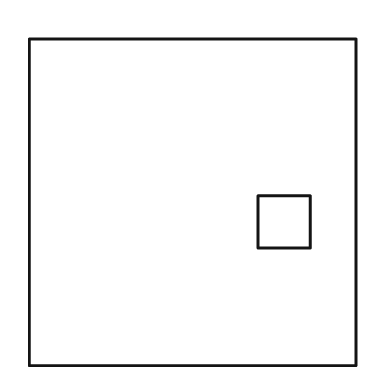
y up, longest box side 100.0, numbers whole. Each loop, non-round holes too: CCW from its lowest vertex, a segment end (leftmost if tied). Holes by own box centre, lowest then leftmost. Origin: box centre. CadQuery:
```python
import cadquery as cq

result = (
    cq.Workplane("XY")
    .moveTo(-50.0, -50.0)
    .lineTo(50.0, -50.0)
    .lineTo(50.0, 50.0)
    .lineTo(-50.0, 50.0)
    .close()
    .moveTo(20.0, -14.0)
    .lineTo(36.0, -14.0)
    .lineTo(36.0, 2.0)
    .lineTo(20.0, 2.0)
    .close()
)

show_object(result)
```